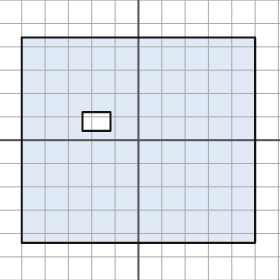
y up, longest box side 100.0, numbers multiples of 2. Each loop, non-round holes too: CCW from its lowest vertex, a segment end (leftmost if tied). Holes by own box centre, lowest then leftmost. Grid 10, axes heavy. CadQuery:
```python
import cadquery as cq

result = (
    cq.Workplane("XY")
    .moveTo(-50.0, -44.0)
    .lineTo(50.0, -44.0)
    .lineTo(50.0, 44.0)
    .lineTo(-50.0, 44.0)
    .close()
    .moveTo(-24.0, 4.0)
    .lineTo(-12.0, 4.0)
    .lineTo(-12.0, 12.0)
    .lineTo(-24.0, 12.0)
    .close()
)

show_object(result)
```